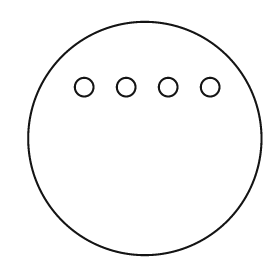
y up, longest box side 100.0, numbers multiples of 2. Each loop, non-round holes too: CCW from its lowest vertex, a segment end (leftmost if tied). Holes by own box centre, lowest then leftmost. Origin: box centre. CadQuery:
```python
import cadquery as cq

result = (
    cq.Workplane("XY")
    .moveTo(0.0, 0.0)
    .circle(50.0)
    .moveTo(-26.0, 22.0)
    .circle(4.0)
    .moveTo(-8.0, 22.0)
    .circle(4.0)
    .moveTo(10.0, 22.0)
    .circle(4.0)
    .moveTo(28.0, 22.0)
    .circle(4.0)
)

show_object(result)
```